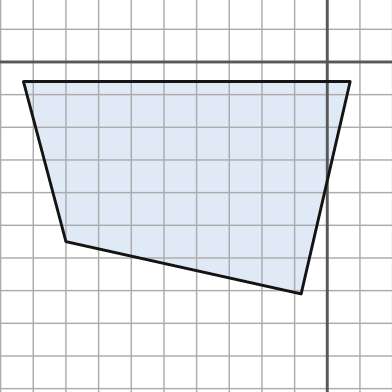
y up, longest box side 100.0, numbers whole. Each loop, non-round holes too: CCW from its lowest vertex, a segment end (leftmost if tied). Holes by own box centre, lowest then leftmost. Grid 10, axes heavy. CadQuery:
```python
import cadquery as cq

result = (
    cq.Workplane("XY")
    .moveTo(-8.0, -71.0)
    .lineTo(7.0, -6.0)
    .lineTo(-93.0, -6.0)
    .lineTo(-80.0, -55.0)
    .close()
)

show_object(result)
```